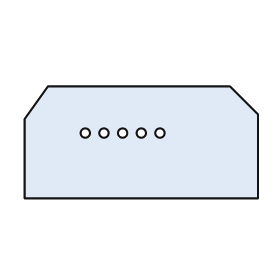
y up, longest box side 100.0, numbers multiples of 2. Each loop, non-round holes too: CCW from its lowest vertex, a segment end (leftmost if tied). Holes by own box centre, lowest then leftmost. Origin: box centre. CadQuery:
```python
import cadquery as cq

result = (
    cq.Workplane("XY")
    .moveTo(-50.0, -24.0)
    .lineTo(50.0, -24.0)
    .lineTo(50.0, 12.0)
    .lineTo(38.0, 24.0)
    .lineTo(-40.0, 24.0)
    .lineTo(-50.0, 10.0)
    .close()
    .moveTo(-24.0, 4.0)
    .circle(2.0)
    .moveTo(-16.0, 4.0)
    .circle(2.0)
    .moveTo(-8.0, 4.0)
    .circle(2.0)
    .moveTo(0.0, 4.0)
    .circle(2.0)
    .moveTo(8.0, 4.0)
    .circle(2.0)
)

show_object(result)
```